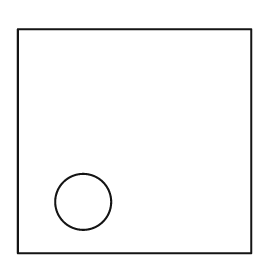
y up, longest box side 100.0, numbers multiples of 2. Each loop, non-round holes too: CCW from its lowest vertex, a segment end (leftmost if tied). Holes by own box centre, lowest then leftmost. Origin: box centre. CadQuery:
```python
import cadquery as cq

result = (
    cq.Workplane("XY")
    .moveTo(-50.0, -48.0)
    .lineTo(50.0, -48.0)
    .lineTo(50.0, 48.0)
    .lineTo(-50.0, 48.0)
    .close()
    .moveTo(-22.0, -26.0)
    .circle(12.0)
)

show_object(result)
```